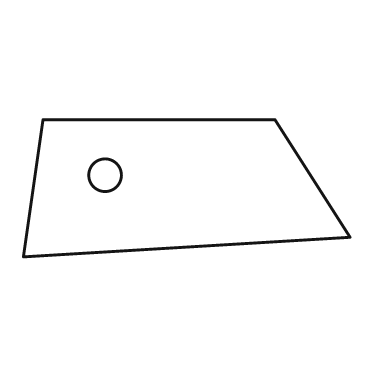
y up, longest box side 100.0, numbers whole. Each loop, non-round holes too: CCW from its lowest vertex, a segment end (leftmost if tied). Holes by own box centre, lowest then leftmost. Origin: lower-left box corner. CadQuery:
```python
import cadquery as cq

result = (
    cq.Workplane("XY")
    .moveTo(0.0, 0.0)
    .lineTo(100.0, 6.0)
    .lineTo(77.0, 42.0)
    .lineTo(6.0, 42.0)
    .close()
    .moveTo(25.0, 25.0)
    .circle(5.0)
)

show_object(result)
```